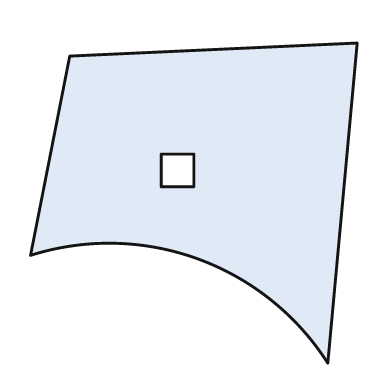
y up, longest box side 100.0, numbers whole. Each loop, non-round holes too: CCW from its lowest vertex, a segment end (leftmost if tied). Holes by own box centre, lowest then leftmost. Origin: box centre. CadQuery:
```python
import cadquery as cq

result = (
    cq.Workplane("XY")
    .moveTo(41.0, -49.0)
    .lineTo(50.0, 49.0)
    .lineTo(-38.0, 45.0)
    .lineTo(-50.0, -16.0)
    .threePointArc((1.0, -17.0), (41.0, -49.0))
    .close()
    .moveTo(-10.0, 5.0)
    .lineTo(0.0, 5.0)
    .lineTo(0.0, 15.0)
    .lineTo(-10.0, 15.0)
    .close()
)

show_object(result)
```